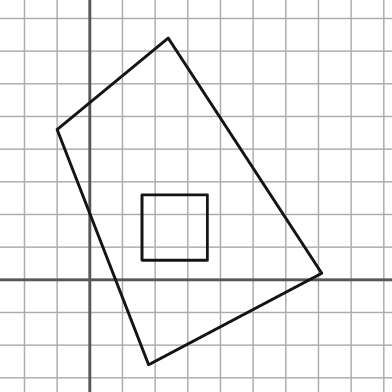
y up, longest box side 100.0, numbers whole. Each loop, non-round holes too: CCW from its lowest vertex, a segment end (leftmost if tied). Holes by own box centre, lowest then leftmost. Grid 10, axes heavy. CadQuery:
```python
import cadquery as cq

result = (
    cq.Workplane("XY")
    .moveTo(18.0, -26.0)
    .lineTo(71.0, 2.0)
    .lineTo(24.0, 74.0)
    .lineTo(-10.0, 46.0)
    .close()
    .moveTo(16.0, 6.0)
    .lineTo(36.0, 6.0)
    .lineTo(36.0, 26.0)
    .lineTo(16.0, 26.0)
    .close()
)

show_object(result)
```